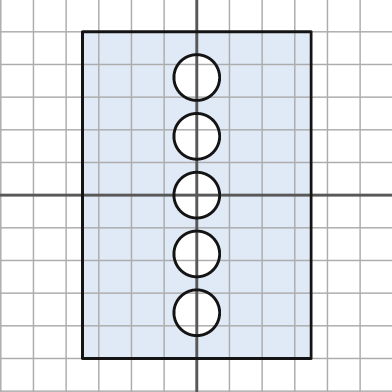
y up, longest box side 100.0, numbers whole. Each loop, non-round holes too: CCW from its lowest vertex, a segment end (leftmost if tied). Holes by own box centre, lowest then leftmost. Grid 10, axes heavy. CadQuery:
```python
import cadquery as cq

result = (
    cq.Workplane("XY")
    .moveTo(-35.0, -50.0)
    .lineTo(35.0, -50.0)
    .lineTo(35.0, 50.0)
    .lineTo(-35.0, 50.0)
    .close()
    .moveTo(0.0, -36.0)
    .circle(7.0)
    .moveTo(0.0, -18.0)
    .circle(7.0)
    .moveTo(0.0, 0.0)
    .circle(7.0)
    .moveTo(0.0, 18.0)
    .circle(7.0)
    .moveTo(0.0, 36.0)
    .circle(7.0)
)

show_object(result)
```